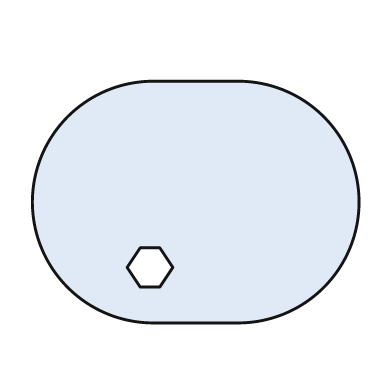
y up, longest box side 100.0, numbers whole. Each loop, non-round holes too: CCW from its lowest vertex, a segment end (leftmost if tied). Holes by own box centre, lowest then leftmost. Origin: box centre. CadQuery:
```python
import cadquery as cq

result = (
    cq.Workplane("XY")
    .moveTo(-13.0, -37.0)
    .lineTo(13.0, -37.0)
    .threePointArc((50.0, 0.0), (13.0, 37.0))
    .lineTo(-13.0, 37.0)
    .threePointArc((-50.0, 0.0), (-13.0, -37.0))
    .close()
    .moveTo(-17.0, -26.0)
    .lineTo(-11.0, -26.0)
    .lineTo(-7.0, -20.0)
    .lineTo(-11.0, -14.0)
    .lineTo(-17.0, -14.0)
    .lineTo(-21.0, -20.0)
    .close()
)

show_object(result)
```